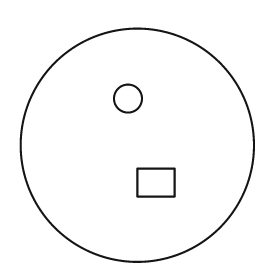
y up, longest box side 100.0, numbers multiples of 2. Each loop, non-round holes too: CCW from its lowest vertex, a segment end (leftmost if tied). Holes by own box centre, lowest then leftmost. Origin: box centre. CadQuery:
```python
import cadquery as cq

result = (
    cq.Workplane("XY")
    .moveTo(0.0, 0.0)
    .circle(50.0)
    .moveTo(0.0, -22.0)
    .lineTo(16.0, -22.0)
    .lineTo(16.0, -10.0)
    .lineTo(0.0, -10.0)
    .close()
    .moveTo(-4.0, 20.0)
    .circle(6.0)
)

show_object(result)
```